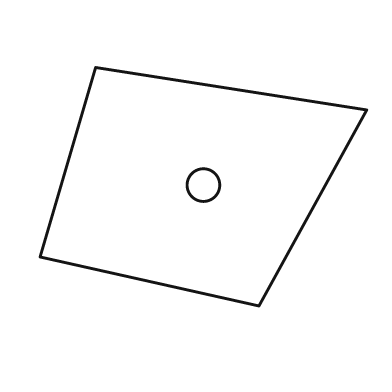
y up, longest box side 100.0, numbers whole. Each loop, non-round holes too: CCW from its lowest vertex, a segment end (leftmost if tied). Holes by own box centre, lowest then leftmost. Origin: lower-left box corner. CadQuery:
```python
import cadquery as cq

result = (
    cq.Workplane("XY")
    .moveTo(67.0, 0.0)
    .lineTo(100.0, 60.0)
    .lineTo(17.0, 73.0)
    .lineTo(0.0, 15.0)
    .close()
    .moveTo(50.0, 37.0)
    .circle(5.0)
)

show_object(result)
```